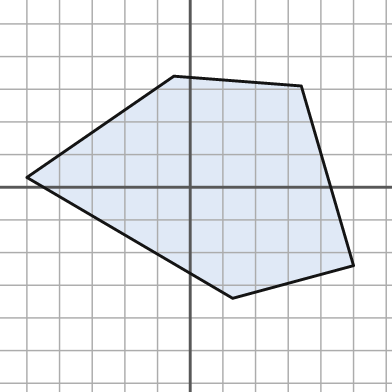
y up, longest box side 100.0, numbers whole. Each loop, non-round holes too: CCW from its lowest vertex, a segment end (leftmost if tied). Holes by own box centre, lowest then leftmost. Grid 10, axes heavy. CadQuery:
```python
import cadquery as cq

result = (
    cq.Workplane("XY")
    .moveTo(13.0, -34.0)
    .lineTo(50.0, -24.0)
    .lineTo(34.0, 31.0)
    .lineTo(-5.0, 34.0)
    .lineTo(-50.0, 3.0)
    .close()
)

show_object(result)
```